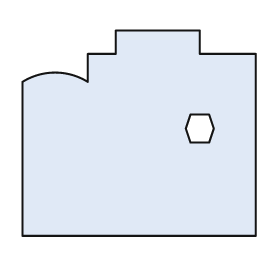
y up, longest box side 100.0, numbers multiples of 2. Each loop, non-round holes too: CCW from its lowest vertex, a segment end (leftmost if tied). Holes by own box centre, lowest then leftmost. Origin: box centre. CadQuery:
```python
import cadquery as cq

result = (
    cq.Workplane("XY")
    .moveTo(-50.0, -44.0)
    .lineTo(50.0, -44.0)
    .lineTo(50.0, 34.0)
    .lineTo(26.0, 34.0)
    .lineTo(26.0, 44.0)
    .lineTo(-10.0, 44.0)
    .lineTo(-10.0, 34.0)
    .lineTo(-22.0, 34.0)
    .lineTo(-22.0, 22.0)
    .threePointArc((-36.0, 26.0), (-50.0, 22.0))
    .close()
    .moveTo(22.0, -4.0)
    .lineTo(30.0, -4.0)
    .lineTo(32.0, 2.0)
    .lineTo(30.0, 8.0)
    .lineTo(22.0, 8.0)
    .lineTo(20.0, 2.0)
    .close()
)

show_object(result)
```